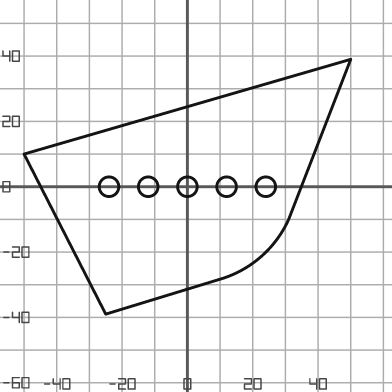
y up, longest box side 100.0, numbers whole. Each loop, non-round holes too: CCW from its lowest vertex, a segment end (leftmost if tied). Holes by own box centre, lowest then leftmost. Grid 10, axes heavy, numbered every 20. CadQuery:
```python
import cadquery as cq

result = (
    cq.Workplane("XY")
    .moveTo(-25.0, -39.0)
    .lineTo(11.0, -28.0)
    .threePointArc((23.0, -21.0), (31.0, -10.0))
    .lineTo(50.0, 39.0)
    .lineTo(-50.0, 10.0)
    .close()
    .moveTo(-24.0, 0.0)
    .circle(3.0)
    .moveTo(-12.0, 0.0)
    .circle(3.0)
    .moveTo(0.0, 0.0)
    .circle(3.0)
    .moveTo(12.0, 0.0)
    .circle(3.0)
    .moveTo(24.0, 0.0)
    .circle(3.0)
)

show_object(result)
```